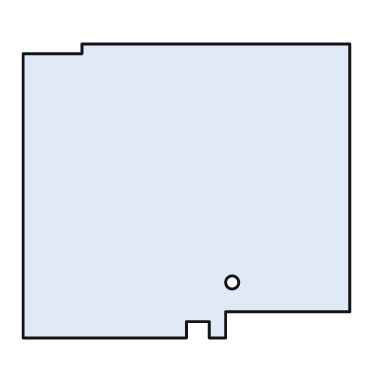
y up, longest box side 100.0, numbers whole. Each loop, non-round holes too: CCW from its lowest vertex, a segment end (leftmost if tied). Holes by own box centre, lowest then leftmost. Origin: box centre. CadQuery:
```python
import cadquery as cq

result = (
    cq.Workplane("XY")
    .moveTo(-50.0, -45.0)
    .lineTo(0.0, -45.0)
    .lineTo(0.0, -40.0)
    .lineTo(7.0, -40.0)
    .lineTo(7.0, -45.0)
    .lineTo(12.0, -45.0)
    .lineTo(12.0, -37.0)
    .lineTo(50.0, -37.0)
    .lineTo(50.0, 45.0)
    .lineTo(-32.0, 45.0)
    .lineTo(-32.0, 42.0)
    .lineTo(-50.0, 42.0)
    .close()
    .moveTo(14.0, -28.0)
    .circle(2.0)
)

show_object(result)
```